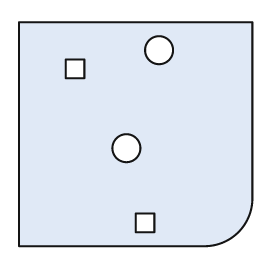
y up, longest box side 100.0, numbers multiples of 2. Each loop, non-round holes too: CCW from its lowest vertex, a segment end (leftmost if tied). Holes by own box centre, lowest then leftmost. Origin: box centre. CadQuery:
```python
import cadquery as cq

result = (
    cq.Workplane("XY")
    .moveTo(-50.0, -48.0)
    .lineTo(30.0, -48.0)
    .threePointArc((44.0, -42.0), (50.0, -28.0))
    .lineTo(50.0, 48.0)
    .lineTo(-50.0, 48.0)
    .close()
    .moveTo(0.0, -42.0)
    .lineTo(8.0, -42.0)
    .lineTo(8.0, -34.0)
    .lineTo(0.0, -34.0)
    .close()
    .moveTo(-4.0, -6.0)
    .circle(6.0)
    .moveTo(-30.0, 24.0)
    .lineTo(-22.0, 24.0)
    .lineTo(-22.0, 32.0)
    .lineTo(-30.0, 32.0)
    .close()
    .moveTo(10.0, 36.0)
    .circle(6.0)
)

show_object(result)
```